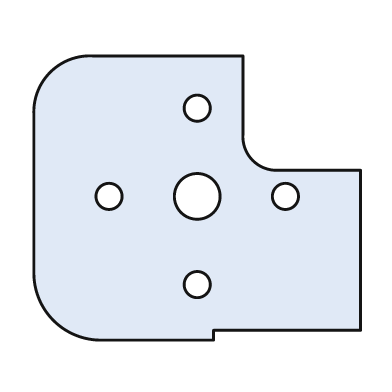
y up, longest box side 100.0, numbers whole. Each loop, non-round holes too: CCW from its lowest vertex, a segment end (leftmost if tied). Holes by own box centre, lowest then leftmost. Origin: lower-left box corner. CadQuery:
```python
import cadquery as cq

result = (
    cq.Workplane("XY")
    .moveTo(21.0, 0.0)
    .lineTo(55.0, 0.0)
    .lineTo(55.0, 3.0)
    .lineTo(100.0, 3.0)
    .lineTo(100.0, 52.0)
    .lineTo(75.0, 52.0)
    .threePointArc((67.0, 55.0), (64.0, 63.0))
    .lineTo(64.0, 87.0)
    .lineTo(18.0, 87.0)
    .threePointArc((5.0, 82.0), (0.0, 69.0))
    .lineTo(0.0, 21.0)
    .threePointArc((6.0, 6.0), (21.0, 0.0))
    .close()
    .moveTo(50.0, 17.0)
    .circle(4.0)
    .moveTo(23.0, 44.0)
    .circle(4.0)
    .moveTo(50.0, 44.0)
    .circle(7.0)
    .moveTo(77.0, 44.0)
    .circle(4.0)
    .moveTo(50.0, 71.0)
    .circle(4.0)
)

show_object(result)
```